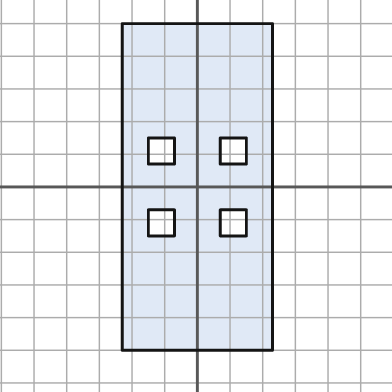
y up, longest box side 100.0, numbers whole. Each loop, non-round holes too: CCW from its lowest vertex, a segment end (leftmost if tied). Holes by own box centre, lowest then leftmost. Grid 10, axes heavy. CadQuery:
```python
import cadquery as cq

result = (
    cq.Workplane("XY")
    .moveTo(-23.0, -50.0)
    .lineTo(23.0, -50.0)
    .lineTo(23.0, 50.0)
    .lineTo(-23.0, 50.0)
    .close()
    .moveTo(-15.0, -15.0)
    .lineTo(-7.0, -15.0)
    .lineTo(-7.0, -7.0)
    .lineTo(-15.0, -7.0)
    .close()
    .moveTo(7.0, -15.0)
    .lineTo(15.0, -15.0)
    .lineTo(15.0, -7.0)
    .lineTo(7.0, -7.0)
    .close()
    .moveTo(-15.0, 7.0)
    .lineTo(-7.0, 7.0)
    .lineTo(-7.0, 15.0)
    .lineTo(-15.0, 15.0)
    .close()
    .moveTo(7.0, 7.0)
    .lineTo(15.0, 7.0)
    .lineTo(15.0, 15.0)
    .lineTo(7.0, 15.0)
    .close()
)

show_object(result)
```